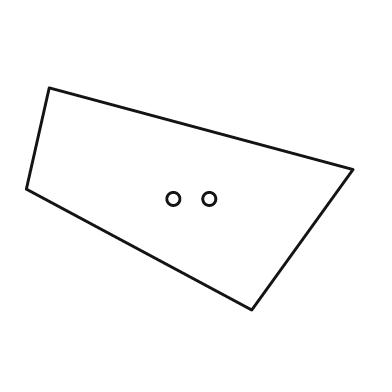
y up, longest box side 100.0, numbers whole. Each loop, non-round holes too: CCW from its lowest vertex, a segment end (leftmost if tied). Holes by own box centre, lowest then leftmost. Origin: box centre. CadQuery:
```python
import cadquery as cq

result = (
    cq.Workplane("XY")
    .moveTo(19.0, -34.0)
    .lineTo(50.0, 9.0)
    .lineTo(-43.0, 34.0)
    .lineTo(-50.0, 3.0)
    .close()
    .moveTo(-5.0, 0.0)
    .circle(2.0)
    .moveTo(6.0, 0.0)
    .circle(2.0)
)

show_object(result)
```